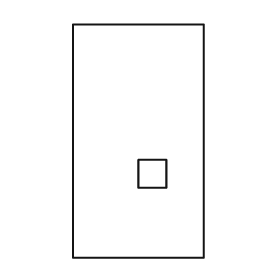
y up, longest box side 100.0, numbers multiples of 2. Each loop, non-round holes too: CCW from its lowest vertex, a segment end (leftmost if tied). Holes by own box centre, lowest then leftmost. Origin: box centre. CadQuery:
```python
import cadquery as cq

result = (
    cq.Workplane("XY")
    .moveTo(-28.0, -50.0)
    .lineTo(28.0, -50.0)
    .lineTo(28.0, 50.0)
    .lineTo(-28.0, 50.0)
    .close()
    .moveTo(0.0, -20.0)
    .lineTo(12.0, -20.0)
    .lineTo(12.0, -8.0)
    .lineTo(0.0, -8.0)
    .close()
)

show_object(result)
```